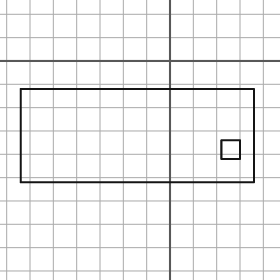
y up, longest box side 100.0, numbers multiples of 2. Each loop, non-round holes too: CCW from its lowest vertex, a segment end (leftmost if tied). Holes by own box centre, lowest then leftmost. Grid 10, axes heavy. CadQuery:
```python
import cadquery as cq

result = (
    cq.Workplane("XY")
    .moveTo(-64.0, -52.0)
    .lineTo(36.0, -52.0)
    .lineTo(36.0, -12.0)
    .lineTo(-64.0, -12.0)
    .close()
    .moveTo(22.0, -42.0)
    .lineTo(30.0, -42.0)
    .lineTo(30.0, -34.0)
    .lineTo(22.0, -34.0)
    .close()
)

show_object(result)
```